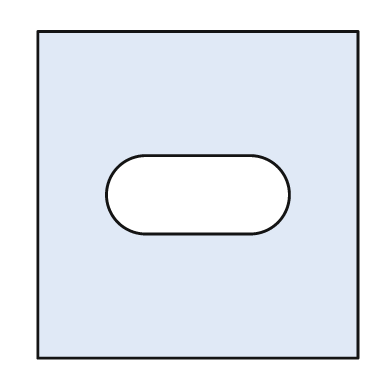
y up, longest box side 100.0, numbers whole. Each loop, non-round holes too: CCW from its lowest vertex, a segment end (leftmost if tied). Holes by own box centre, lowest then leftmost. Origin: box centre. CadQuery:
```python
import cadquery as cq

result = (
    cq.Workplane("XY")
    .moveTo(-49.0, -50.0)
    .lineTo(49.0, -50.0)
    .lineTo(49.0, 50.0)
    .lineTo(-49.0, 50.0)
    .close()
    .moveTo(-16.0, -12.0)
    .lineTo(16.0, -12.0)
    .threePointArc((28.0, 0.0), (16.0, 12.0))
    .lineTo(-16.0, 12.0)
    .threePointArc((-28.0, 0.0), (-16.0, -12.0))
    .close()
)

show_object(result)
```